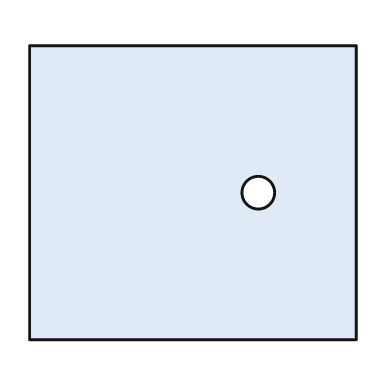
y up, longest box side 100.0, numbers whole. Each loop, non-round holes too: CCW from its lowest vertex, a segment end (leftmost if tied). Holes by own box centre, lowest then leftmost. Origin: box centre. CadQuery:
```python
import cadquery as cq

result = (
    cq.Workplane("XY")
    .moveTo(-50.0, -45.0)
    .lineTo(50.0, -45.0)
    .lineTo(50.0, 45.0)
    .lineTo(-50.0, 45.0)
    .close()
    .moveTo(20.0, 0.0)
    .circle(5.0)
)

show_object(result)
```